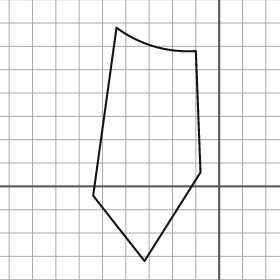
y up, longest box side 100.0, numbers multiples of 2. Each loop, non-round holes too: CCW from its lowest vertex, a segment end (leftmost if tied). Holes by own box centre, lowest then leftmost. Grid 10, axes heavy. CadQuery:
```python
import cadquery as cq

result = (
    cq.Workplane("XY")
    .moveTo(-32.0, -32.0)
    .lineTo(-8.0, 6.0)
    .lineTo(-10.0, 58.0)
    .threePointArc((-28.0, 60.0), (-44.0, 68.0))
    .lineTo(-54.0, -4.0)
    .close()
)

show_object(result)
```